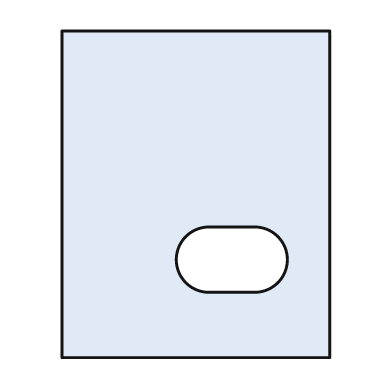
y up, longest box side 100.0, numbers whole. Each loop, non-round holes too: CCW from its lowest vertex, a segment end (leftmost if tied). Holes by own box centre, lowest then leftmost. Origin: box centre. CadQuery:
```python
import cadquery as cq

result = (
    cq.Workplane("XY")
    .moveTo(-41.0, -50.0)
    .lineTo(41.0, -50.0)
    .lineTo(41.0, 50.0)
    .lineTo(-41.0, 50.0)
    .close()
    .moveTo(4.0, -30.0)
    .lineTo(18.0, -30.0)
    .threePointArc((28.0, -20.0), (18.0, -10.0))
    .lineTo(4.0, -10.0)
    .threePointArc((-6.0, -20.0), (4.0, -30.0))
    .close()
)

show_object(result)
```